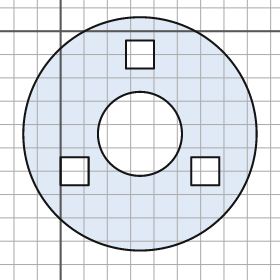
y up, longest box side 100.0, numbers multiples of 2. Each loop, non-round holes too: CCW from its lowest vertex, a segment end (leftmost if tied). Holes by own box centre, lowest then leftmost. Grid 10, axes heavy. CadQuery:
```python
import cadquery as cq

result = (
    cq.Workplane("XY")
    .moveTo(34.0, -44.0)
    .circle(50.0)
    .moveTo(0.0, -66.0)
    .lineTo(12.0, -66.0)
    .lineTo(12.0, -54.0)
    .lineTo(0.0, -54.0)
    .close()
    .moveTo(56.0, -66.0)
    .lineTo(68.0, -66.0)
    .lineTo(68.0, -54.0)
    .lineTo(56.0, -54.0)
    .close()
    .moveTo(34.0, -44.0)
    .circle(18.0)
    .moveTo(28.0, -16.0)
    .lineTo(40.0, -16.0)
    .lineTo(40.0, -4.0)
    .lineTo(28.0, -4.0)
    .close()
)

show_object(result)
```